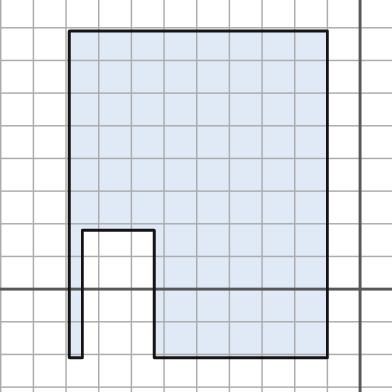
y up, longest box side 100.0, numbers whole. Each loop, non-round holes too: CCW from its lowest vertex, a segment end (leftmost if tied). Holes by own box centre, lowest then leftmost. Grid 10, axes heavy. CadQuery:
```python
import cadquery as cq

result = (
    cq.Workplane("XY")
    .moveTo(-89.0, -21.0)
    .lineTo(-85.0, -21.0)
    .lineTo(-85.0, 18.0)
    .lineTo(-63.0, 18.0)
    .lineTo(-63.0, -21.0)
    .lineTo(-10.0, -21.0)
    .lineTo(-10.0, 79.0)
    .lineTo(-89.0, 79.0)
    .close()
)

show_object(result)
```